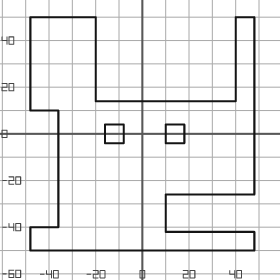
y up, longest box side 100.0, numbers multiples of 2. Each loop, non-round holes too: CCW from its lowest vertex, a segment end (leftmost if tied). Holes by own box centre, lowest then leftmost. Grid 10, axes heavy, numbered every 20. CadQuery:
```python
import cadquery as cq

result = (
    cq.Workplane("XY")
    .moveTo(-48.0, -50.0)
    .lineTo(48.0, -50.0)
    .lineTo(48.0, -42.0)
    .lineTo(10.0, -42.0)
    .lineTo(10.0, -26.0)
    .lineTo(48.0, -26.0)
    .lineTo(48.0, 50.0)
    .lineTo(40.0, 50.0)
    .lineTo(40.0, 14.0)
    .lineTo(-20.0, 14.0)
    .lineTo(-20.0, 50.0)
    .lineTo(-48.0, 50.0)
    .lineTo(-48.0, 10.0)
    .lineTo(-36.0, 10.0)
    .lineTo(-36.0, -40.0)
    .lineTo(-48.0, -40.0)
    .close()
    .moveTo(-16.0, -4.0)
    .lineTo(-8.0, -4.0)
    .lineTo(-8.0, 4.0)
    .lineTo(-16.0, 4.0)
    .close()
    .moveTo(10.0, -4.0)
    .lineTo(18.0, -4.0)
    .lineTo(18.0, 4.0)
    .lineTo(10.0, 4.0)
    .close()
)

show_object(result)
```